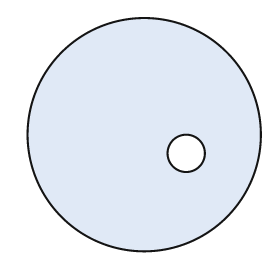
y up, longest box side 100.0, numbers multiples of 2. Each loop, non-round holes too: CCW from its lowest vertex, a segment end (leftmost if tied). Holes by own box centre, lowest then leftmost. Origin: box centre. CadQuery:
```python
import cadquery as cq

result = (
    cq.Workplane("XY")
    .moveTo(0.0, 0.0)
    .circle(50.0)
    .moveTo(18.0, -8.0)
    .circle(8.0)
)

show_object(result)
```